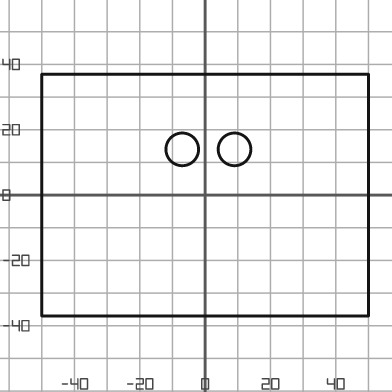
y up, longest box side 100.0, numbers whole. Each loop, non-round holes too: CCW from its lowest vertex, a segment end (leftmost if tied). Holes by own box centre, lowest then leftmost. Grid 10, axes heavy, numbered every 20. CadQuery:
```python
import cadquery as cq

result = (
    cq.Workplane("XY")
    .moveTo(-50.0, -37.0)
    .lineTo(50.0, -37.0)
    .lineTo(50.0, 37.0)
    .lineTo(-50.0, 37.0)
    .close()
    .moveTo(-7.0, 14.0)
    .circle(5.0)
    .moveTo(9.0, 14.0)
    .circle(5.0)
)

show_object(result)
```